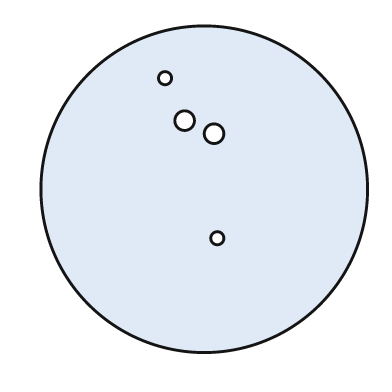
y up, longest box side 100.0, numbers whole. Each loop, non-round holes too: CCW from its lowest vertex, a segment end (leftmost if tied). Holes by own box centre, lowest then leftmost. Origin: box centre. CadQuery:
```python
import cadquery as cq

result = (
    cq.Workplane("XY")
    .moveTo(0.0, 0.0)
    .circle(50.0)
    .moveTo(4.0, -15.0)
    .circle(2.0)
    .moveTo(3.0, 17.0)
    .circle(3.0)
    .moveTo(-6.0, 21.0)
    .circle(3.0)
    .moveTo(-12.0, 34.0)
    .circle(2.0)
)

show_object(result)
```